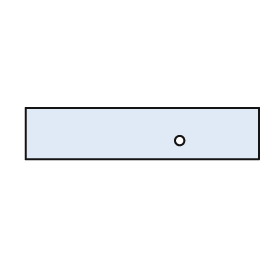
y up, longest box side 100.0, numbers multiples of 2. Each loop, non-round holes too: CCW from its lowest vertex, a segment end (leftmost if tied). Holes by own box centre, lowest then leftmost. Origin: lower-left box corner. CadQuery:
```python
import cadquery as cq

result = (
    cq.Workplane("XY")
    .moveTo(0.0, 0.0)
    .lineTo(100.0, 0.0)
    .lineTo(100.0, 22.0)
    .lineTo(0.0, 22.0)
    .close()
    .moveTo(66.0, 8.0)
    .circle(2.0)
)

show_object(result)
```